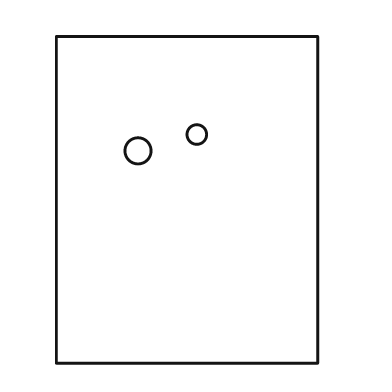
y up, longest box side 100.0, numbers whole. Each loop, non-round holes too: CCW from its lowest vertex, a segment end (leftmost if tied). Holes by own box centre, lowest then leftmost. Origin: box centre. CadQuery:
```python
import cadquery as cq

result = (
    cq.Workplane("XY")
    .moveTo(-40.0, -50.0)
    .lineTo(40.0, -50.0)
    .lineTo(40.0, 50.0)
    .lineTo(-40.0, 50.0)
    .close()
    .moveTo(-15.0, 15.0)
    .circle(4.0)
    .moveTo(3.0, 20.0)
    .circle(3.0)
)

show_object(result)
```